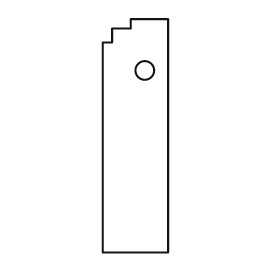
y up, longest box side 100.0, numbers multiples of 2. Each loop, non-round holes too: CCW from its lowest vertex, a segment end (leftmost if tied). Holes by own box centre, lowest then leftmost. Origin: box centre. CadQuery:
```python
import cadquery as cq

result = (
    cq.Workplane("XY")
    .moveTo(-14.0, -50.0)
    .lineTo(14.0, -50.0)
    .lineTo(14.0, 50.0)
    .lineTo(-2.0, 50.0)
    .lineTo(-2.0, 46.0)
    .lineTo(-10.0, 46.0)
    .lineTo(-10.0, 40.0)
    .lineTo(-14.0, 40.0)
    .close()
    .moveTo(4.0, 28.0)
    .circle(4.0)
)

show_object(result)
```